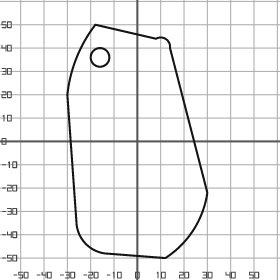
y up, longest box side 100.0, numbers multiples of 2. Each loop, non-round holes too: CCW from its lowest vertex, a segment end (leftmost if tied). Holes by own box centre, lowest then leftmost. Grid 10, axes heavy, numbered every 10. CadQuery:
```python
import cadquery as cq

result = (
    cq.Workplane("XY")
    .moveTo(12.0, -50.0)
    .threePointArc((24.0, -38.0), (30.0, -22.0))
    .lineTo(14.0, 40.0)
    .threePointArc((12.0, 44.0), (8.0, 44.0))
    .lineTo(-18.0, 50.0)
    .threePointArc((-26.0, 36.0), (-30.0, 20.0))
    .lineTo(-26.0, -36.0)
    .threePointArc((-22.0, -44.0), (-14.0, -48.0))
    .close()
    .moveTo(-16.0, 36.0)
    .circle(4.0)
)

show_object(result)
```